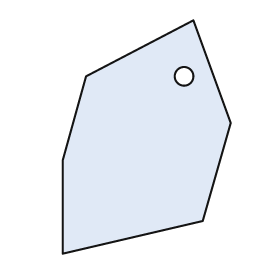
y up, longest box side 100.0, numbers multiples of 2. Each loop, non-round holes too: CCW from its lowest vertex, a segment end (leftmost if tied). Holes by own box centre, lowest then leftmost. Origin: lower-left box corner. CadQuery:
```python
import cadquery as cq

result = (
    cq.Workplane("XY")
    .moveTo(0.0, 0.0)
    .lineTo(60.0, 14.0)
    .lineTo(72.0, 56.0)
    .lineTo(56.0, 100.0)
    .lineTo(10.0, 76.0)
    .lineTo(0.0, 40.0)
    .close()
    .moveTo(52.0, 76.0)
    .circle(4.0)
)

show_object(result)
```